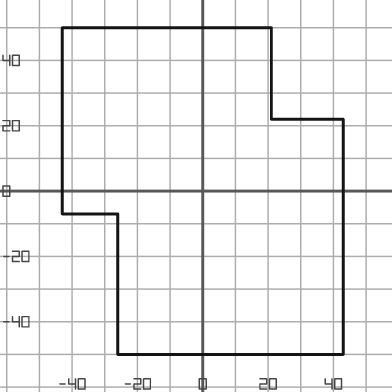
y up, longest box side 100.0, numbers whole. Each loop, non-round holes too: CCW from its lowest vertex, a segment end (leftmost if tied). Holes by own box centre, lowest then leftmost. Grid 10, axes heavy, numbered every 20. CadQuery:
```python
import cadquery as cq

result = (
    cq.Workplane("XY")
    .moveTo(-26.0, -50.0)
    .lineTo(43.0, -50.0)
    .lineTo(43.0, 22.0)
    .lineTo(21.0, 22.0)
    .lineTo(21.0, 50.0)
    .lineTo(-43.0, 50.0)
    .lineTo(-43.0, -7.0)
    .lineTo(-26.0, -7.0)
    .close()
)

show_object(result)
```